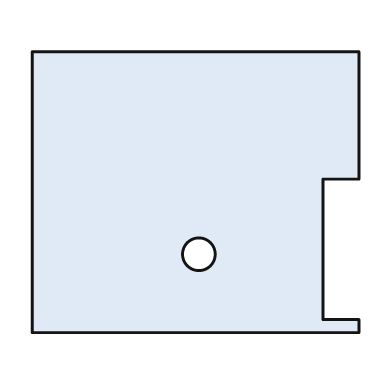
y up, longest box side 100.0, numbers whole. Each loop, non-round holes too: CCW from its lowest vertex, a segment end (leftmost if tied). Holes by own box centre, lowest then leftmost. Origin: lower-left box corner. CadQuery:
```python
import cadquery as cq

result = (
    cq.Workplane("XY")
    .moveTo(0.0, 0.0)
    .lineTo(100.0, 0.0)
    .lineTo(100.0, 4.0)
    .lineTo(89.0, 4.0)
    .lineTo(89.0, 47.0)
    .lineTo(100.0, 47.0)
    .lineTo(100.0, 86.0)
    .lineTo(0.0, 86.0)
    .close()
    .moveTo(51.0, 24.0)
    .circle(5.0)
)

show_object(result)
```